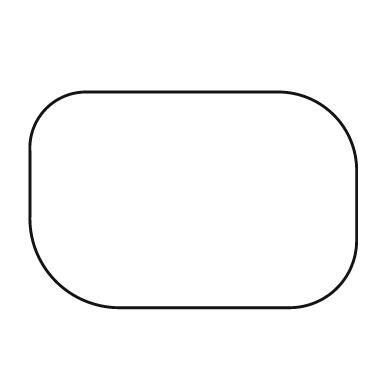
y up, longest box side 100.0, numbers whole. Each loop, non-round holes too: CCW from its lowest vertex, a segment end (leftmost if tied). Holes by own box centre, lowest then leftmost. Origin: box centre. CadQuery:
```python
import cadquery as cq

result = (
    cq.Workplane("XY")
    .moveTo(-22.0, -33.0)
    .lineTo(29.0, -33.0)
    .threePointArc((44.0, -27.0), (50.0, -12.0))
    .lineTo(50.0, 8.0)
    .threePointArc((43.0, 26.0), (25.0, 33.0))
    .lineTo(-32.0, 33.0)
    .threePointArc((-45.0, 28.0), (-50.0, 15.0))
    .lineTo(-50.0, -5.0)
    .threePointArc((-42.0, -25.0), (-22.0, -33.0))
    .close()
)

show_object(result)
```